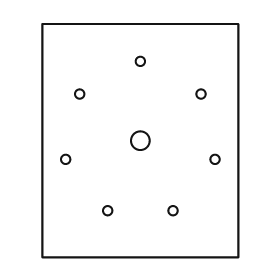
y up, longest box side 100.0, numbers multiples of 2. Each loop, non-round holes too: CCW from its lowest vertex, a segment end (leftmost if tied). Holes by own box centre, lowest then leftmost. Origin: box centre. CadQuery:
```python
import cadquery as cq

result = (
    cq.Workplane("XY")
    .moveTo(-42.0, -50.0)
    .lineTo(42.0, -50.0)
    .lineTo(42.0, 50.0)
    .lineTo(-42.0, 50.0)
    .close()
    .moveTo(-14.0, -30.0)
    .circle(2.0)
    .moveTo(14.0, -30.0)
    .circle(2.0)
    .moveTo(-32.0, -8.0)
    .circle(2.0)
    .moveTo(32.0, -8.0)
    .circle(2.0)
    .moveTo(0.0, 0.0)
    .circle(4.0)
    .moveTo(-26.0, 20.0)
    .circle(2.0)
    .moveTo(26.0, 20.0)
    .circle(2.0)
    .moveTo(0.0, 34.0)
    .circle(2.0)
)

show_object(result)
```